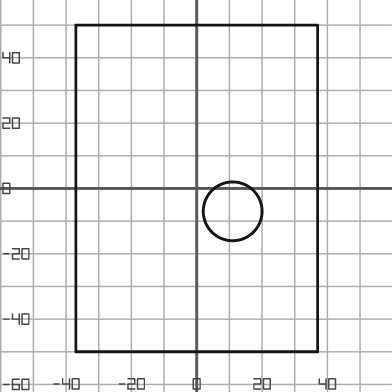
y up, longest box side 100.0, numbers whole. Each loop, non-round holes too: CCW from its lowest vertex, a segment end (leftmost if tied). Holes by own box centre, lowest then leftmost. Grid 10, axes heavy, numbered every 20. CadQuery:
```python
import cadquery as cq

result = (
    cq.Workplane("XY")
    .moveTo(-37.0, -50.0)
    .lineTo(37.0, -50.0)
    .lineTo(37.0, 50.0)
    .lineTo(-37.0, 50.0)
    .close()
    .moveTo(11.0, -7.0)
    .circle(9.0)
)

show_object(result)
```